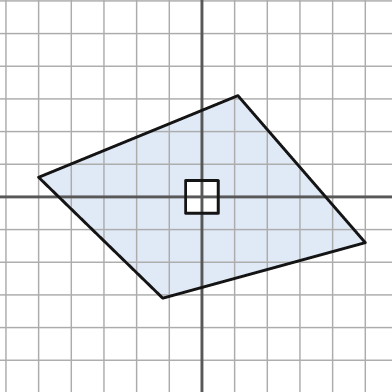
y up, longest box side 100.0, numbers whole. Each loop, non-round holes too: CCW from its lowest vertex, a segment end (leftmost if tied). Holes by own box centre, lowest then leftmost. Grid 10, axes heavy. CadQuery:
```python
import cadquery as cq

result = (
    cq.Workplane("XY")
    .moveTo(-12.0, -31.0)
    .lineTo(50.0, -14.0)
    .lineTo(11.0, 31.0)
    .lineTo(-50.0, 6.0)
    .close()
    .moveTo(-5.0, -5.0)
    .lineTo(5.0, -5.0)
    .lineTo(5.0, 5.0)
    .lineTo(-5.0, 5.0)
    .close()
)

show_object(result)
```